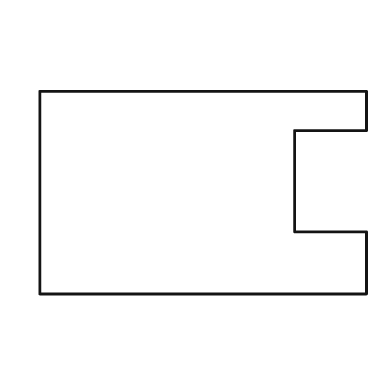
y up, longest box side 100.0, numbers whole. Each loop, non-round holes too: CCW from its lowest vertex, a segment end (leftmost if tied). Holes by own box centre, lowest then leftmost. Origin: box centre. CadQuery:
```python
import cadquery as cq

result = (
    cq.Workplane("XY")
    .moveTo(-50.0, -31.0)
    .lineTo(50.0, -31.0)
    .lineTo(50.0, -12.0)
    .lineTo(28.0, -12.0)
    .lineTo(28.0, 19.0)
    .lineTo(50.0, 19.0)
    .lineTo(50.0, 31.0)
    .lineTo(-50.0, 31.0)
    .close()
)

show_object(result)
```